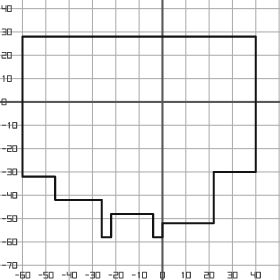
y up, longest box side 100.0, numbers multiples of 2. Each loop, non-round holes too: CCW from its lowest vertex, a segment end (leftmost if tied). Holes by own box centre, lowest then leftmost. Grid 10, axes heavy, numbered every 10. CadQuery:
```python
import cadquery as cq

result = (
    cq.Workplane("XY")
    .moveTo(-26.0, -58.0)
    .lineTo(-22.0, -58.0)
    .lineTo(-22.0, -48.0)
    .lineTo(-4.0, -48.0)
    .lineTo(-4.0, -58.0)
    .lineTo(0.0, -58.0)
    .lineTo(0.0, -52.0)
    .lineTo(22.0, -52.0)
    .lineTo(22.0, -30.0)
    .lineTo(40.0, -30.0)
    .lineTo(40.0, 28.0)
    .lineTo(-60.0, 28.0)
    .lineTo(-60.0, -32.0)
    .lineTo(-46.0, -32.0)
    .lineTo(-46.0, -42.0)
    .lineTo(-26.0, -42.0)
    .close()
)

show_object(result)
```